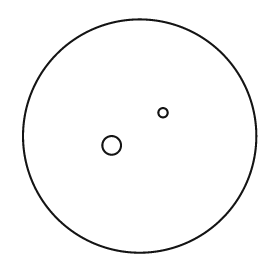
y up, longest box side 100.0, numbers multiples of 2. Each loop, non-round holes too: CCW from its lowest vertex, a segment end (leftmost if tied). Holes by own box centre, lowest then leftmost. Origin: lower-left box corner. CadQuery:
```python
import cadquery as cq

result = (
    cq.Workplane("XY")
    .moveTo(50.0, 50.0)
    .circle(50.0)
    .moveTo(38.0, 46.0)
    .circle(4.0)
    .moveTo(60.0, 60.0)
    .circle(2.0)
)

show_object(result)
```